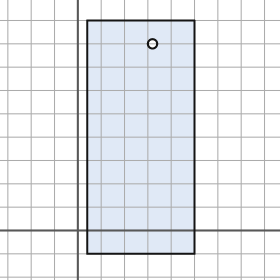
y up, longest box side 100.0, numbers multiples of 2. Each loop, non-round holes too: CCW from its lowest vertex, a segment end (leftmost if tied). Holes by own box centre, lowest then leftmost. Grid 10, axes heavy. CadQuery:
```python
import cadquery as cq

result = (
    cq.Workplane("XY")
    .moveTo(4.0, -10.0)
    .lineTo(50.0, -10.0)
    .lineTo(50.0, 90.0)
    .lineTo(4.0, 90.0)
    .close()
    .moveTo(32.0, 80.0)
    .circle(2.0)
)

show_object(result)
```